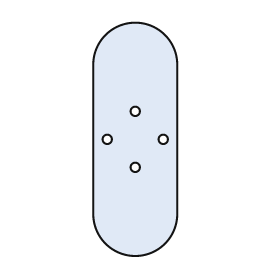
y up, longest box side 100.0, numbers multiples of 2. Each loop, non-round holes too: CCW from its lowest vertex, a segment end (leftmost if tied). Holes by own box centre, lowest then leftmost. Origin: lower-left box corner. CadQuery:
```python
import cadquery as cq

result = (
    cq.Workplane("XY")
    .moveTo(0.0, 18.0)
    .threePointArc((18.0, 0.0), (36.0, 18.0))
    .lineTo(36.0, 82.0)
    .threePointArc((18.0, 100.0), (0.0, 82.0))
    .close()
    .moveTo(18.0, 38.0)
    .circle(2.0)
    .moveTo(6.0, 50.0)
    .circle(2.0)
    .moveTo(30.0, 50.0)
    .circle(2.0)
    .moveTo(18.0, 62.0)
    .circle(2.0)
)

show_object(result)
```